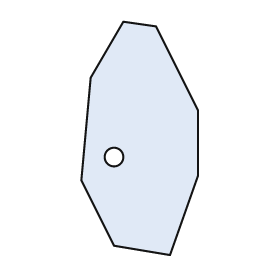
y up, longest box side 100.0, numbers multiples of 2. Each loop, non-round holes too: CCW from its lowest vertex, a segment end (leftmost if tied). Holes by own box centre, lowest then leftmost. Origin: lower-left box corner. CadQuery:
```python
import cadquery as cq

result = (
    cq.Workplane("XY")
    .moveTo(38.0, 0.0)
    .lineTo(50.0, 34.0)
    .lineTo(50.0, 62.0)
    .lineTo(32.0, 98.0)
    .lineTo(18.0, 100.0)
    .lineTo(4.0, 76.0)
    .lineTo(0.0, 32.0)
    .lineTo(14.0, 4.0)
    .close()
    .moveTo(14.0, 42.0)
    .circle(4.0)
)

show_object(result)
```